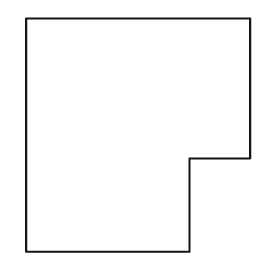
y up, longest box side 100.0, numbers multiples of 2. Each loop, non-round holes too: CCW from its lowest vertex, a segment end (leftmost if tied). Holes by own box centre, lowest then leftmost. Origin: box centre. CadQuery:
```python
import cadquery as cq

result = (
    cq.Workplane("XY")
    .moveTo(-48.0, -50.0)
    .lineTo(22.0, -50.0)
    .lineTo(22.0, -10.0)
    .lineTo(48.0, -10.0)
    .lineTo(48.0, 50.0)
    .lineTo(-48.0, 50.0)
    .close()
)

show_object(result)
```